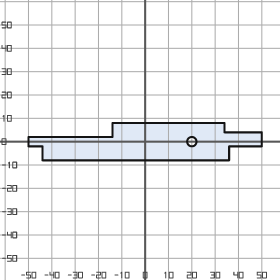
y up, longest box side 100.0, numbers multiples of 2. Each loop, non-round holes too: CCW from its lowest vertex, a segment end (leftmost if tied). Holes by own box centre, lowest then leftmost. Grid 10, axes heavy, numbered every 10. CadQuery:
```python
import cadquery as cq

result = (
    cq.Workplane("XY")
    .moveTo(-44.0, -8.0)
    .lineTo(36.0, -8.0)
    .lineTo(36.0, -2.0)
    .lineTo(50.0, -2.0)
    .lineTo(50.0, 4.0)
    .lineTo(34.0, 4.0)
    .lineTo(34.0, 8.0)
    .lineTo(-14.0, 8.0)
    .lineTo(-14.0, 2.0)
    .lineTo(-50.0, 2.0)
    .lineTo(-50.0, -2.0)
    .lineTo(-44.0, -2.0)
    .close()
    .moveTo(20.0, 0.0)
    .circle(2.0)
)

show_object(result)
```